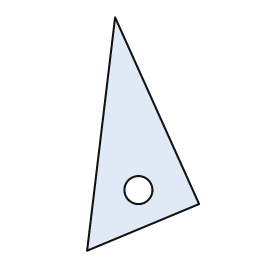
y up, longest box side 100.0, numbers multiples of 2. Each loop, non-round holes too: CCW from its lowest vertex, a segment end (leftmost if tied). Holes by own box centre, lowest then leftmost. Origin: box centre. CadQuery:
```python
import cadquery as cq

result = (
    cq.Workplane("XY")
    .moveTo(-24.0, -50.0)
    .lineTo(24.0, -30.0)
    .lineTo(-12.0, 50.0)
    .close()
    .moveTo(-2.0, -24.0)
    .circle(6.0)
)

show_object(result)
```